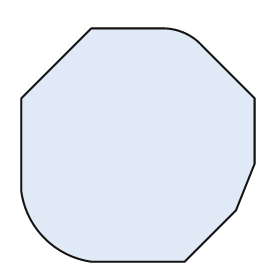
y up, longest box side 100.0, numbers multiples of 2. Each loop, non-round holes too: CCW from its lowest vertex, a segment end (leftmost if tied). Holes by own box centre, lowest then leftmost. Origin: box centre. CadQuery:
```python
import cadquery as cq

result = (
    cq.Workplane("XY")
    .moveTo(-20.0, -50.0)
    .lineTo(20.0, -50.0)
    .lineTo(42.0, -28.0)
    .lineTo(50.0, -8.0)
    .lineTo(50.0, 20.0)
    .lineTo(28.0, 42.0)
    .threePointArc((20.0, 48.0), (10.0, 50.0))
    .lineTo(-20.0, 50.0)
    .lineTo(-50.0, 20.0)
    .lineTo(-50.0, -20.0)
    .threePointArc((-40.0, -40.0), (-20.0, -50.0))
    .close()
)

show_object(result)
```